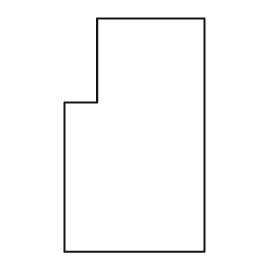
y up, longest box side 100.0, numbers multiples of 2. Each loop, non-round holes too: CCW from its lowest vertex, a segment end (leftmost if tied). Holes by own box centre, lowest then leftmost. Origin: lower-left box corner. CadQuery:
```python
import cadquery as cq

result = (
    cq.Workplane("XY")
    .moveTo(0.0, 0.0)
    .lineTo(60.0, 0.0)
    .lineTo(60.0, 100.0)
    .lineTo(14.0, 100.0)
    .lineTo(14.0, 64.0)
    .lineTo(0.0, 64.0)
    .close()
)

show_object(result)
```